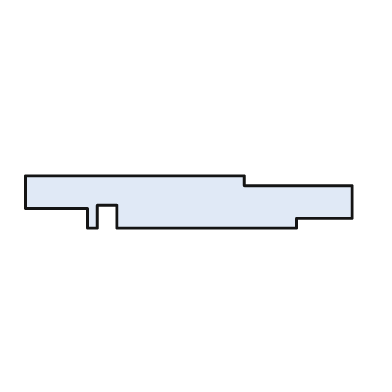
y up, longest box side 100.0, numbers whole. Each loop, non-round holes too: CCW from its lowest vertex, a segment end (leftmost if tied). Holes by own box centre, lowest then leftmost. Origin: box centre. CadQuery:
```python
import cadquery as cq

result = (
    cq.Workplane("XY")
    .moveTo(-31.0, -8.0)
    .lineTo(-28.0, -8.0)
    .lineTo(-28.0, -1.0)
    .lineTo(-22.0, -1.0)
    .lineTo(-22.0, -8.0)
    .lineTo(33.0, -8.0)
    .lineTo(33.0, -5.0)
    .lineTo(50.0, -5.0)
    .lineTo(50.0, 5.0)
    .lineTo(17.0, 5.0)
    .lineTo(17.0, 8.0)
    .lineTo(-50.0, 8.0)
    .lineTo(-50.0, -2.0)
    .lineTo(-31.0, -2.0)
    .close()
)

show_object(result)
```